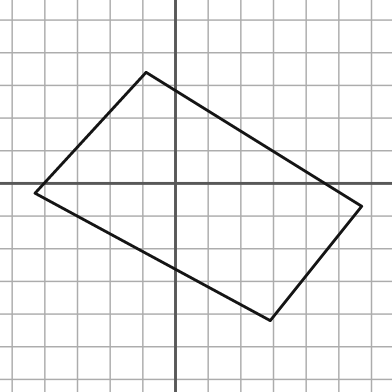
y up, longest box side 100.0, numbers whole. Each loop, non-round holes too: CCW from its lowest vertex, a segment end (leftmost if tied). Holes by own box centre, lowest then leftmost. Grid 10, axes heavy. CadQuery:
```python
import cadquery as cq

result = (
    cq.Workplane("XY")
    .moveTo(29.0, -42.0)
    .lineTo(57.0, -7.0)
    .lineTo(-9.0, 34.0)
    .lineTo(-43.0, -3.0)
    .close()
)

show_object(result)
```